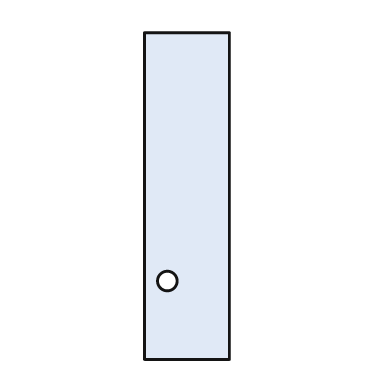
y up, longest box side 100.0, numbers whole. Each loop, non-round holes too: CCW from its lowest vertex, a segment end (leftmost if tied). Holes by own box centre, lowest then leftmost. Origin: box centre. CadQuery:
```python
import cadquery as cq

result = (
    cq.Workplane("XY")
    .moveTo(-13.0, -50.0)
    .lineTo(13.0, -50.0)
    .lineTo(13.0, 50.0)
    .lineTo(-13.0, 50.0)
    .close()
    .moveTo(-6.0, -26.0)
    .circle(3.0)
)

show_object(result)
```